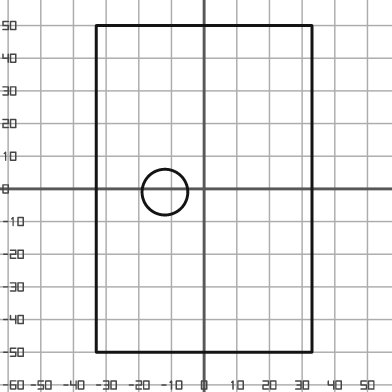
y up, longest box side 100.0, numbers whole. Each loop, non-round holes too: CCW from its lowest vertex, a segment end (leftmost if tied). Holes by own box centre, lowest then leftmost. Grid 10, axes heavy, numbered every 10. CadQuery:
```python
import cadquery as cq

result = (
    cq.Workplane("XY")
    .moveTo(-33.0, -50.0)
    .lineTo(33.0, -50.0)
    .lineTo(33.0, 50.0)
    .lineTo(-33.0, 50.0)
    .close()
    .moveTo(-12.0, -1.0)
    .circle(7.0)
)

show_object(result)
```